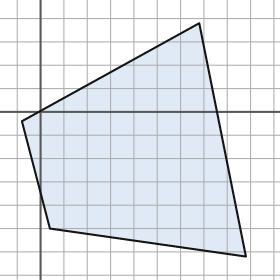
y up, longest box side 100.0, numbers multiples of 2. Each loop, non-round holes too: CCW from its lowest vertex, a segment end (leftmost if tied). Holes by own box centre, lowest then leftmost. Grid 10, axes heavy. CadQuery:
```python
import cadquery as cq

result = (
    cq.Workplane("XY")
    .moveTo(88.0, -62.0)
    .lineTo(68.0, 38.0)
    .lineTo(-8.0, -4.0)
    .lineTo(4.0, -50.0)
    .close()
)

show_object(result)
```